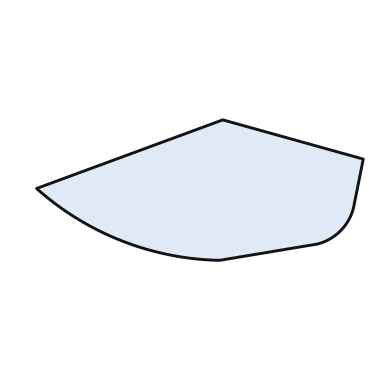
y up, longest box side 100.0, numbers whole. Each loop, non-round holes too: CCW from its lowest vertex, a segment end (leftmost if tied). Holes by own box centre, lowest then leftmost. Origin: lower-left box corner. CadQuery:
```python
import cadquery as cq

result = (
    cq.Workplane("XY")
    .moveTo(56.0, 0.0)
    .lineTo(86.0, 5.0)
    .threePointArc((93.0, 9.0), (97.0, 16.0))
    .lineTo(100.0, 31.0)
    .lineTo(57.0, 43.0)
    .lineTo(0.0, 22.0)
    .threePointArc((26.0, 6.0), (56.0, 0.0))
    .close()
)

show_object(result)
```